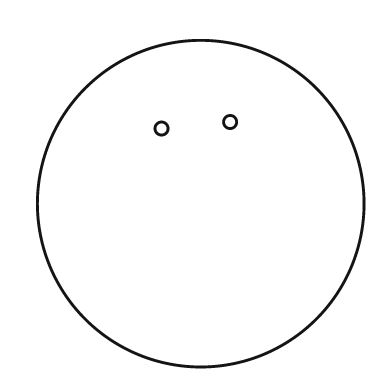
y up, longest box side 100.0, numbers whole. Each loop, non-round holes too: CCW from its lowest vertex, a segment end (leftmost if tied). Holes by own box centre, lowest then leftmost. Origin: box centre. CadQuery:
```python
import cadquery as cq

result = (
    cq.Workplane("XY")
    .moveTo(0.0, 0.0)
    .circle(50.0)
    .moveTo(-12.0, 23.0)
    .circle(2.0)
    .moveTo(9.0, 25.0)
    .circle(2.0)
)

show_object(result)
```